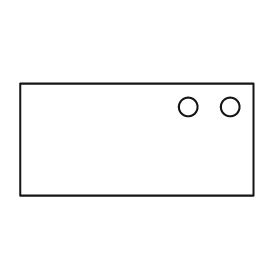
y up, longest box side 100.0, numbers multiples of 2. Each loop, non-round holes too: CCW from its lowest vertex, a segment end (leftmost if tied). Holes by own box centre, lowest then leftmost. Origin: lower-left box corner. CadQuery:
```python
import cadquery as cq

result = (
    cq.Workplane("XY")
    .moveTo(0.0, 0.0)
    .lineTo(100.0, 0.0)
    .lineTo(100.0, 48.0)
    .lineTo(0.0, 48.0)
    .close()
    .moveTo(72.0, 38.0)
    .circle(4.0)
    .moveTo(90.0, 38.0)
    .circle(4.0)
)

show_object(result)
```